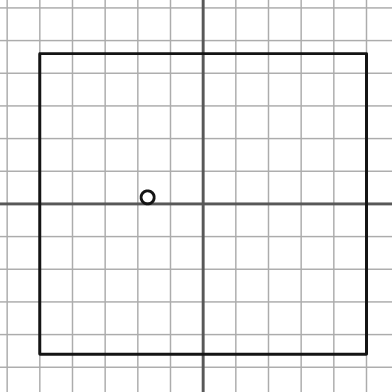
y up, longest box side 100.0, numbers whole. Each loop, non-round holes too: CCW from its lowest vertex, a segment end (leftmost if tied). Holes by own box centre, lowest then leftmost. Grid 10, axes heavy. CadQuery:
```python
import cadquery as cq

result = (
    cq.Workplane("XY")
    .moveTo(-50.0, -46.0)
    .lineTo(50.0, -46.0)
    .lineTo(50.0, 46.0)
    .lineTo(-50.0, 46.0)
    .close()
    .moveTo(-17.0, 2.0)
    .circle(2.0)
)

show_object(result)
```